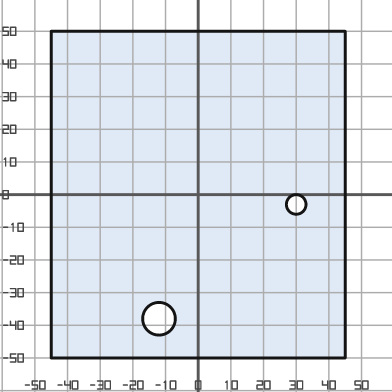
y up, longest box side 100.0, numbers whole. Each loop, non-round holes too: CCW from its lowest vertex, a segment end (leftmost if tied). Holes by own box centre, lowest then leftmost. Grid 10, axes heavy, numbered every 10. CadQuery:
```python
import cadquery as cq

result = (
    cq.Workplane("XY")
    .moveTo(-45.0, -50.0)
    .lineTo(45.0, -50.0)
    .lineTo(45.0, 50.0)
    .lineTo(-45.0, 50.0)
    .close()
    .moveTo(-12.0, -38.0)
    .circle(5.0)
    .moveTo(30.0, -3.0)
    .circle(3.0)
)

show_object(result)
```